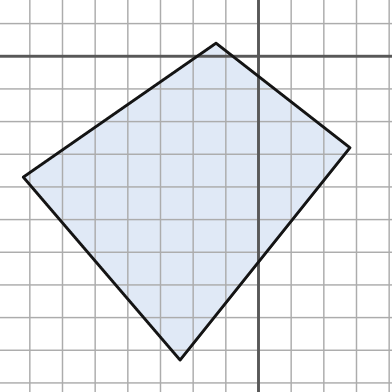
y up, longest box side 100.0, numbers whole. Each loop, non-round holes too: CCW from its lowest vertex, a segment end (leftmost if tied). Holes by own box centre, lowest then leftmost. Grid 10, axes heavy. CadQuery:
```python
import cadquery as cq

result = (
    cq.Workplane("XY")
    .moveTo(-24.0, -93.0)
    .lineTo(28.0, -28.0)
    .lineTo(-13.0, 4.0)
    .lineTo(-72.0, -37.0)
    .close()
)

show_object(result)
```